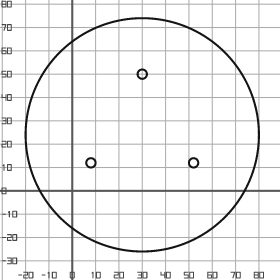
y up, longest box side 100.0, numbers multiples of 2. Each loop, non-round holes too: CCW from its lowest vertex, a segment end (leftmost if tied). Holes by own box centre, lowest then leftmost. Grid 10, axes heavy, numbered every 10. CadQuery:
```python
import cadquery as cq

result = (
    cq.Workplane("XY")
    .moveTo(30.0, 24.0)
    .circle(50.0)
    .moveTo(8.0, 12.0)
    .circle(2.0)
    .moveTo(52.0, 12.0)
    .circle(2.0)
    .moveTo(30.0, 50.0)
    .circle(2.0)
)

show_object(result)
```